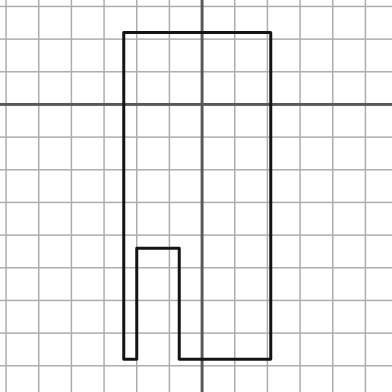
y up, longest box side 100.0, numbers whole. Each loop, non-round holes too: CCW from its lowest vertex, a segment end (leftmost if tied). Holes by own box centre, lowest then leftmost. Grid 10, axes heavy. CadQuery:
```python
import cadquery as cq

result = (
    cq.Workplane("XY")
    .moveTo(-24.0, -78.0)
    .lineTo(-20.0, -78.0)
    .lineTo(-20.0, -44.0)
    .lineTo(-7.0, -44.0)
    .lineTo(-7.0, -78.0)
    .lineTo(21.0, -78.0)
    .lineTo(21.0, 22.0)
    .lineTo(-24.0, 22.0)
    .close()
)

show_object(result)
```